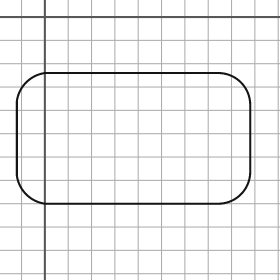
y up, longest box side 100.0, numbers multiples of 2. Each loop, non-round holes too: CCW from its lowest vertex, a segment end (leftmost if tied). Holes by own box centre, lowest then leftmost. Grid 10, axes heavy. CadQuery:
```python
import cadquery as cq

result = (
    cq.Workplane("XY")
    .moveTo(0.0, -80.0)
    .lineTo(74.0, -80.0)
    .threePointArc((84.0, -76.0), (88.0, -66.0))
    .lineTo(88.0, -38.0)
    .threePointArc((84.0, -28.0), (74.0, -24.0))
    .lineTo(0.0, -24.0)
    .threePointArc((-8.0, -28.0), (-12.0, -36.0))
    .lineTo(-12.0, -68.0)
    .threePointArc((-8.0, -76.0), (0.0, -80.0))
    .close()
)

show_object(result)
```